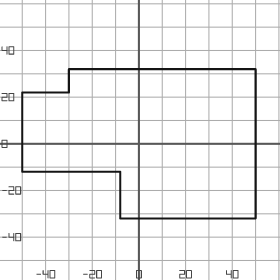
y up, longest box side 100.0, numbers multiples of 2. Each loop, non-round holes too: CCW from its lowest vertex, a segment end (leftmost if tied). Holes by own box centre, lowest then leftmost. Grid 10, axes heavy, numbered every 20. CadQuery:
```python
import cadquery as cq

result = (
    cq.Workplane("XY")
    .moveTo(-8.0, -32.0)
    .lineTo(50.0, -32.0)
    .lineTo(50.0, 32.0)
    .lineTo(-30.0, 32.0)
    .lineTo(-30.0, 22.0)
    .lineTo(-50.0, 22.0)
    .lineTo(-50.0, -12.0)
    .lineTo(-8.0, -12.0)
    .close()
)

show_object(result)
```